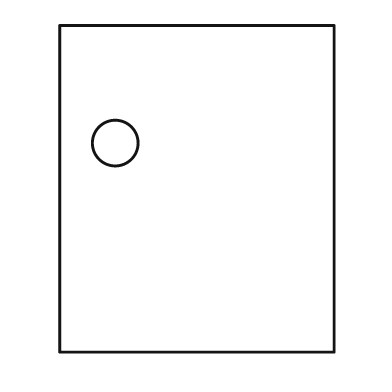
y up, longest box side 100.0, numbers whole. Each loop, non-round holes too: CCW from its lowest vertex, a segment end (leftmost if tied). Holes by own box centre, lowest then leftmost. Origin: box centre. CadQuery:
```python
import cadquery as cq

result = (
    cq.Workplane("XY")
    .moveTo(-42.0, -50.0)
    .lineTo(42.0, -50.0)
    .lineTo(42.0, 50.0)
    .lineTo(-42.0, 50.0)
    .close()
    .moveTo(-25.0, 14.0)
    .circle(7.0)
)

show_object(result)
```